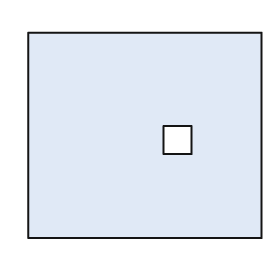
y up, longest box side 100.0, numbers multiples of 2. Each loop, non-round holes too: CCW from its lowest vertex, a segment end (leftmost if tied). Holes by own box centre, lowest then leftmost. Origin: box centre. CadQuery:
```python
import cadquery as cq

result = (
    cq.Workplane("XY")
    .moveTo(-50.0, -44.0)
    .lineTo(50.0, -44.0)
    .lineTo(50.0, 44.0)
    .lineTo(-50.0, 44.0)
    .close()
    .moveTo(8.0, -8.0)
    .lineTo(20.0, -8.0)
    .lineTo(20.0, 4.0)
    .lineTo(8.0, 4.0)
    .close()
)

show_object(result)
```